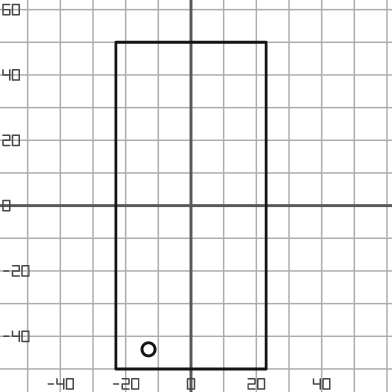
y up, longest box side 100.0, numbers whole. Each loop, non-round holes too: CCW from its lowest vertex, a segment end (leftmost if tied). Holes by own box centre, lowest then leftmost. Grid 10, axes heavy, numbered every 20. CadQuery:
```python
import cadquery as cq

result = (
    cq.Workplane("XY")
    .moveTo(-23.0, -50.0)
    .lineTo(23.0, -50.0)
    .lineTo(23.0, 50.0)
    .lineTo(-23.0, 50.0)
    .close()
    .moveTo(-13.0, -44.0)
    .circle(2.0)
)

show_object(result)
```